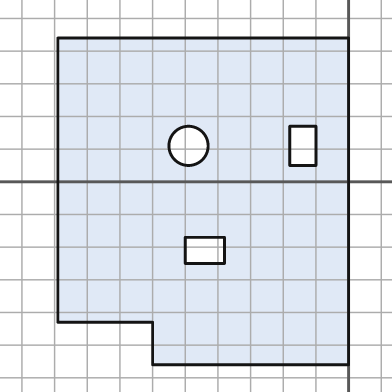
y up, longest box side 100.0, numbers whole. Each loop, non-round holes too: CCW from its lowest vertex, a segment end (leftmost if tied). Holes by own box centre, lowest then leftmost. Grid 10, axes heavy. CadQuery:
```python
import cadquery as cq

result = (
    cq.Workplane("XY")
    .moveTo(-60.0, -56.0)
    .lineTo(0.0, -56.0)
    .lineTo(0.0, 44.0)
    .lineTo(-89.0, 44.0)
    .lineTo(-89.0, -43.0)
    .lineTo(-60.0, -43.0)
    .close()
    .moveTo(-50.0, -25.0)
    .lineTo(-38.0, -25.0)
    .lineTo(-38.0, -17.0)
    .lineTo(-50.0, -17.0)
    .close()
    .moveTo(-49.0, 11.0)
    .circle(6.0)
    .moveTo(-18.0, 5.0)
    .lineTo(-10.0, 5.0)
    .lineTo(-10.0, 17.0)
    .lineTo(-18.0, 17.0)
    .close()
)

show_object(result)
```